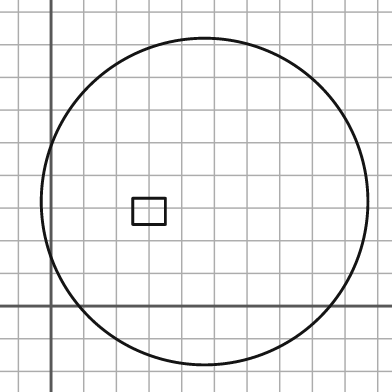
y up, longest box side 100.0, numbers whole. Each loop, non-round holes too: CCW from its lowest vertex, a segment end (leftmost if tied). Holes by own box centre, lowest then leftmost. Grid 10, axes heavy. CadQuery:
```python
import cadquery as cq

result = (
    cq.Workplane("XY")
    .moveTo(47.0, 32.0)
    .circle(50.0)
    .moveTo(25.0, 25.0)
    .lineTo(35.0, 25.0)
    .lineTo(35.0, 33.0)
    .lineTo(25.0, 33.0)
    .close()
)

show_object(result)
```